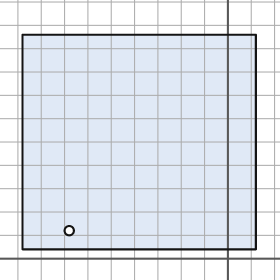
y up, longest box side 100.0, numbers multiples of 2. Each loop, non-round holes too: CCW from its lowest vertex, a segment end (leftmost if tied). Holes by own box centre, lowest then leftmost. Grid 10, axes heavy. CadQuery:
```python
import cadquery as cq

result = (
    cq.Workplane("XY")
    .moveTo(-88.0, 4.0)
    .lineTo(12.0, 4.0)
    .lineTo(12.0, 96.0)
    .lineTo(-88.0, 96.0)
    .close()
    .moveTo(-68.0, 12.0)
    .circle(2.0)
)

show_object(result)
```